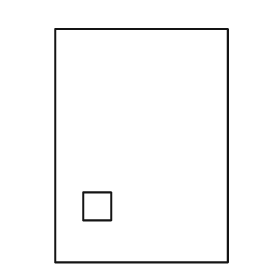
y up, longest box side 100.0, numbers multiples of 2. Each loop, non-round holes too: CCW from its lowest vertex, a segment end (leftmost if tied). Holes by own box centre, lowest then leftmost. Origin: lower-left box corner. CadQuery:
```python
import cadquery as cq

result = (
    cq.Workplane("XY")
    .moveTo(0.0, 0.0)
    .lineTo(74.0, 0.0)
    .lineTo(74.0, 100.0)
    .lineTo(0.0, 100.0)
    .close()
    .moveTo(12.0, 18.0)
    .lineTo(24.0, 18.0)
    .lineTo(24.0, 30.0)
    .lineTo(12.0, 30.0)
    .close()
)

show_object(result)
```